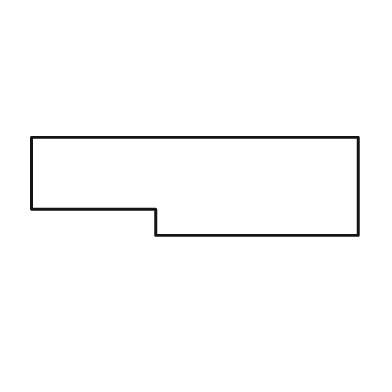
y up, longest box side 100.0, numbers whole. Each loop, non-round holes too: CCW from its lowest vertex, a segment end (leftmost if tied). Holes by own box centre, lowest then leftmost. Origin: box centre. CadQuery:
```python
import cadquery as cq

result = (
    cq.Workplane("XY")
    .moveTo(-12.0, -15.0)
    .lineTo(50.0, -15.0)
    .lineTo(50.0, 15.0)
    .lineTo(-50.0, 15.0)
    .lineTo(-50.0, -7.0)
    .lineTo(-12.0, -7.0)
    .close()
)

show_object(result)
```